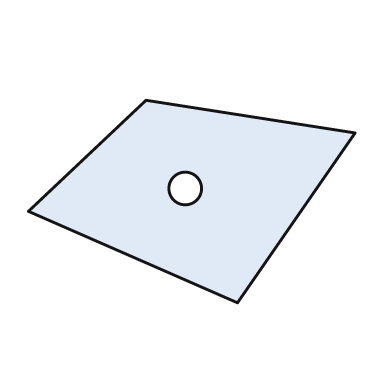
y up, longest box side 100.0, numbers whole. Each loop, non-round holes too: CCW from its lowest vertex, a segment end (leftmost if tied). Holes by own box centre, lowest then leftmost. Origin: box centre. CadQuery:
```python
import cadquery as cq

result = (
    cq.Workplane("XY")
    .moveTo(14.0, -31.0)
    .lineTo(50.0, 21.0)
    .lineTo(-14.0, 31.0)
    .lineTo(-50.0, -3.0)
    .close()
    .moveTo(-2.0, 4.0)
    .circle(5.0)
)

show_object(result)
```